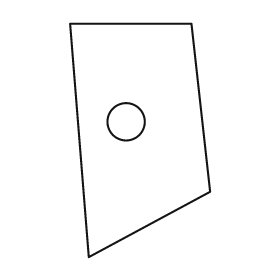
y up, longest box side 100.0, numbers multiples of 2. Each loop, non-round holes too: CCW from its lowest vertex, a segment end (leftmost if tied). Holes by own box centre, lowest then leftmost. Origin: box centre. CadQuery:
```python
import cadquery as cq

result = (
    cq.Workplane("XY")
    .moveTo(-22.0, -50.0)
    .lineTo(30.0, -22.0)
    .lineTo(22.0, 50.0)
    .lineTo(-30.0, 50.0)
    .close()
    .moveTo(-6.0, 8.0)
    .circle(8.0)
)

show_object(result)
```